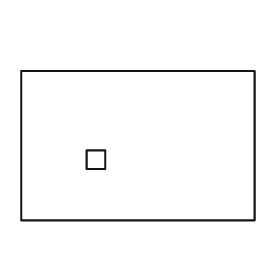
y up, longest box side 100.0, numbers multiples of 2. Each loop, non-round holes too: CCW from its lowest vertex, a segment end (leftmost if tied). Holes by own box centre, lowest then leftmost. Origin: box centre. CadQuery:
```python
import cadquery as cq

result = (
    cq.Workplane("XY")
    .moveTo(-50.0, -32.0)
    .lineTo(50.0, -32.0)
    .lineTo(50.0, 32.0)
    .lineTo(-50.0, 32.0)
    .close()
    .moveTo(-22.0, -10.0)
    .lineTo(-14.0, -10.0)
    .lineTo(-14.0, -2.0)
    .lineTo(-22.0, -2.0)
    .close()
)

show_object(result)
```